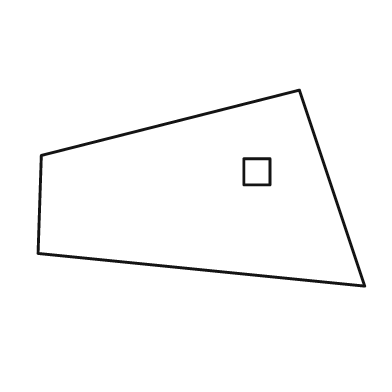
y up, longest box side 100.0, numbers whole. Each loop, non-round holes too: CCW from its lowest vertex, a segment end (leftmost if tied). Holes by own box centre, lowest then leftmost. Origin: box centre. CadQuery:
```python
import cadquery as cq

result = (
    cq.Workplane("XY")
    .moveTo(50.0, -30.0)
    .lineTo(30.0, 30.0)
    .lineTo(-49.0, 10.0)
    .lineTo(-50.0, -20.0)
    .close()
    .moveTo(13.0, 1.0)
    .lineTo(21.0, 1.0)
    .lineTo(21.0, 9.0)
    .lineTo(13.0, 9.0)
    .close()
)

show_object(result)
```